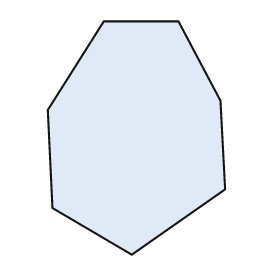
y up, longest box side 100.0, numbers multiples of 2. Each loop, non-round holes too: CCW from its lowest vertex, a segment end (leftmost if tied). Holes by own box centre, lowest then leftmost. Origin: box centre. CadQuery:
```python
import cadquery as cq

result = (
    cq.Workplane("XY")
    .moveTo(-2.0, -50.0)
    .lineTo(38.0, -22.0)
    .lineTo(36.0, 16.0)
    .lineTo(18.0, 50.0)
    .lineTo(-14.0, 50.0)
    .lineTo(-38.0, 12.0)
    .lineTo(-36.0, -30.0)
    .close()
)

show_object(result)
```